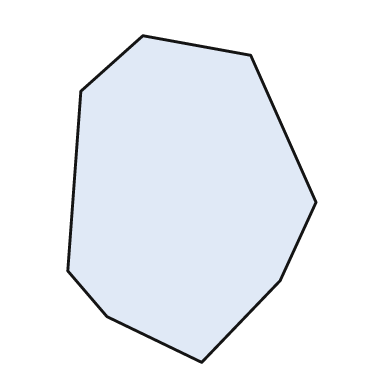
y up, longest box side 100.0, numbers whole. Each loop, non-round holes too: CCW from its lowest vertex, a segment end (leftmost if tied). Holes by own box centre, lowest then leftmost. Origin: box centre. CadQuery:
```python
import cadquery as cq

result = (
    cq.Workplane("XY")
    .moveTo(3.0, -50.0)
    .lineTo(27.0, -25.0)
    .lineTo(38.0, -1.0)
    .lineTo(18.0, 44.0)
    .lineTo(-15.0, 50.0)
    .lineTo(-34.0, 33.0)
    .lineTo(-38.0, -22.0)
    .lineTo(-26.0, -36.0)
    .close()
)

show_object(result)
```